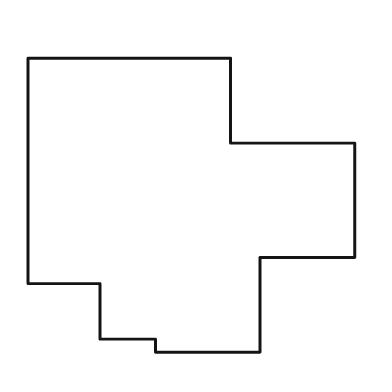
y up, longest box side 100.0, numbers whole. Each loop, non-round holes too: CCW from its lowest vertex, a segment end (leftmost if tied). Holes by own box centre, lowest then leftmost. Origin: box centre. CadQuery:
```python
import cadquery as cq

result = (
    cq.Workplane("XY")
    .moveTo(-11.0, -45.0)
    .lineTo(21.0, -45.0)
    .lineTo(21.0, -16.0)
    .lineTo(50.0, -16.0)
    .lineTo(50.0, 19.0)
    .lineTo(12.0, 19.0)
    .lineTo(12.0, 45.0)
    .lineTo(-50.0, 45.0)
    .lineTo(-50.0, -24.0)
    .lineTo(-28.0, -24.0)
    .lineTo(-28.0, -41.0)
    .lineTo(-11.0, -41.0)
    .close()
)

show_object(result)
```